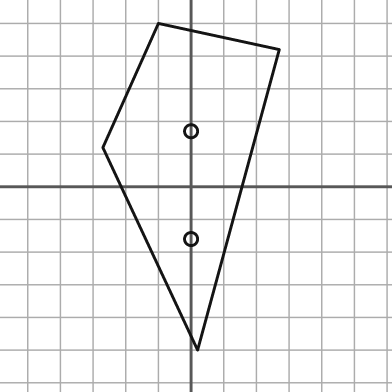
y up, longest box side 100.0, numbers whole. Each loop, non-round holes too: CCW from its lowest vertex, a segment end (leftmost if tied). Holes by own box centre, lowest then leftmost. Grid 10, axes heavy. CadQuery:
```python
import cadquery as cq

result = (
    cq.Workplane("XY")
    .moveTo(2.0, -50.0)
    .lineTo(27.0, 42.0)
    .lineTo(-10.0, 50.0)
    .lineTo(-27.0, 12.0)
    .close()
    .moveTo(0.0, -16.0)
    .circle(2.0)
    .moveTo(0.0, 17.0)
    .circle(2.0)
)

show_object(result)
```